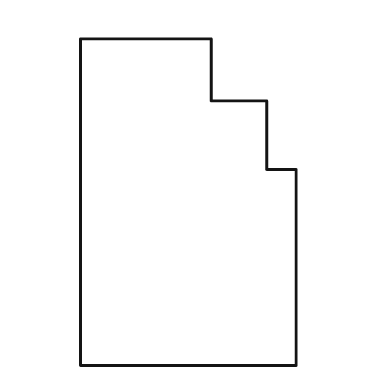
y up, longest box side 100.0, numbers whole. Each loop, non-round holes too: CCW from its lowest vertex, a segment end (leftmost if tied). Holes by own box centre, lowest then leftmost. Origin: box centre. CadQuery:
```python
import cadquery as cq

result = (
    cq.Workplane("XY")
    .moveTo(-33.0, -50.0)
    .lineTo(33.0, -50.0)
    .lineTo(33.0, 10.0)
    .lineTo(24.0, 10.0)
    .lineTo(24.0, 31.0)
    .lineTo(7.0, 31.0)
    .lineTo(7.0, 50.0)
    .lineTo(-33.0, 50.0)
    .close()
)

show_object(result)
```